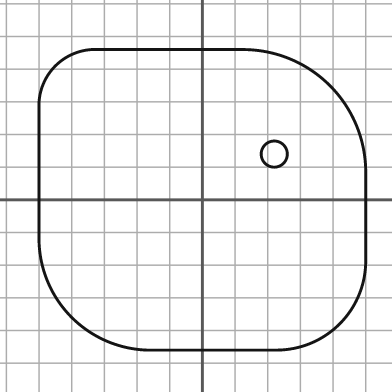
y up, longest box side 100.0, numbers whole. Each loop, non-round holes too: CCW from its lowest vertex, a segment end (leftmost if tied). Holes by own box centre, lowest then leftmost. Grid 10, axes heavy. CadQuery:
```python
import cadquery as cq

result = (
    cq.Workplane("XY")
    .moveTo(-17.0, -46.0)
    .lineTo(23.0, -46.0)
    .threePointArc((42.0, -38.0), (50.0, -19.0))
    .lineTo(50.0, 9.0)
    .threePointArc((39.0, 35.0), (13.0, 46.0))
    .lineTo(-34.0, 46.0)
    .threePointArc((-45.0, 41.0), (-50.0, 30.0))
    .lineTo(-50.0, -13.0)
    .threePointArc((-40.0, -36.0), (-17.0, -46.0))
    .close()
    .moveTo(22.0, 14.0)
    .circle(4.0)
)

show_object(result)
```